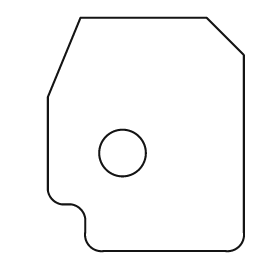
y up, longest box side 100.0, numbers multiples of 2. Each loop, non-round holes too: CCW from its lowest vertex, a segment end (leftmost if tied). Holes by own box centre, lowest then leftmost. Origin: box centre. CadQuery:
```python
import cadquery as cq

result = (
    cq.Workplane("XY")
    .moveTo(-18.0, -50.0)
    .lineTo(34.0, -50.0)
    .threePointArc((40.0, -48.0), (42.0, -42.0))
    .lineTo(42.0, 34.0)
    .lineTo(26.0, 50.0)
    .lineTo(-28.0, 50.0)
    .lineTo(-42.0, 16.0)
    .lineTo(-42.0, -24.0)
    .threePointArc((-40.0, -28.0), (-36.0, -30.0))
    .lineTo(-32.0, -30.0)
    .threePointArc((-28.0, -32.0), (-26.0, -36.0))
    .lineTo(-26.0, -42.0)
    .threePointArc((-24.0, -48.0), (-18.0, -50.0))
    .close()
    .moveTo(-10.0, -8.0)
    .circle(10.0)
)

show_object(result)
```